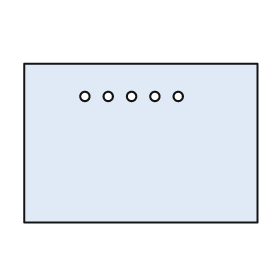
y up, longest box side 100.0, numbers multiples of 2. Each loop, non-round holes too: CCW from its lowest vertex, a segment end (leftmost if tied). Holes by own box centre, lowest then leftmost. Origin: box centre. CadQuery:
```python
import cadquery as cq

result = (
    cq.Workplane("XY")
    .moveTo(-50.0, -34.0)
    .lineTo(50.0, -34.0)
    .lineTo(50.0, 34.0)
    .lineTo(-50.0, 34.0)
    .close()
    .moveTo(-24.0, 20.0)
    .circle(2.0)
    .moveTo(-14.0, 20.0)
    .circle(2.0)
    .moveTo(-4.0, 20.0)
    .circle(2.0)
    .moveTo(6.0, 20.0)
    .circle(2.0)
    .moveTo(16.0, 20.0)
    .circle(2.0)
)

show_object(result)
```